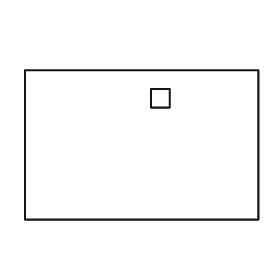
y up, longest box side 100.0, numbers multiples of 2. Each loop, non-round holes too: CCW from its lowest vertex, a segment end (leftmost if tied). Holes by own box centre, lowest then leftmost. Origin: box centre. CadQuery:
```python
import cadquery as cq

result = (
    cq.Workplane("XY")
    .moveTo(-50.0, -32.0)
    .lineTo(50.0, -32.0)
    .lineTo(50.0, 32.0)
    .lineTo(-50.0, 32.0)
    .close()
    .moveTo(4.0, 16.0)
    .lineTo(12.0, 16.0)
    .lineTo(12.0, 24.0)
    .lineTo(4.0, 24.0)
    .close()
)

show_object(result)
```